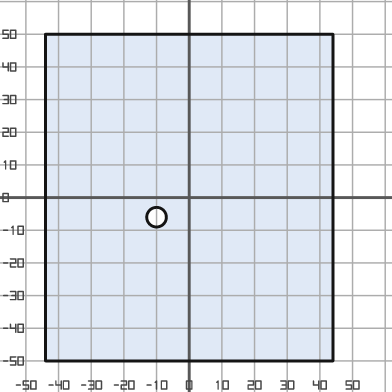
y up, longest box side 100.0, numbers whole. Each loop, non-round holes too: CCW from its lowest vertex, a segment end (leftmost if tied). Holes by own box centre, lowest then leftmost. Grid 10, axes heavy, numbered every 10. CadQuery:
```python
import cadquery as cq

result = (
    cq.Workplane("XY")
    .moveTo(-44.0, -50.0)
    .lineTo(44.0, -50.0)
    .lineTo(44.0, 50.0)
    .lineTo(-44.0, 50.0)
    .close()
    .moveTo(-10.0, -6.0)
    .circle(3.0)
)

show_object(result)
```